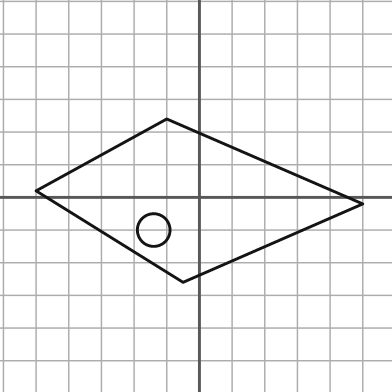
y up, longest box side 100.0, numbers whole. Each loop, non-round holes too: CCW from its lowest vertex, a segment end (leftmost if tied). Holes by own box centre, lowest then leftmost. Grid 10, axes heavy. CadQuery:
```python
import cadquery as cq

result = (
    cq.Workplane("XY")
    .moveTo(-5.0, -26.0)
    .lineTo(50.0, -2.0)
    .lineTo(-10.0, 24.0)
    .lineTo(-50.0, 2.0)
    .close()
    .moveTo(-14.0, -10.0)
    .circle(5.0)
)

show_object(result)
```